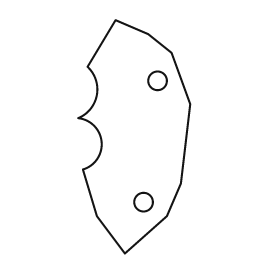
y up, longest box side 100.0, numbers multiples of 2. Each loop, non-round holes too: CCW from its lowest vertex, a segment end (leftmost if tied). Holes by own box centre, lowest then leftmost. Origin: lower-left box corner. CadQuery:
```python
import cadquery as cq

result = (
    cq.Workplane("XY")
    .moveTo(20.0, 0.0)
    .lineTo(38.0, 16.0)
    .lineTo(44.0, 30.0)
    .lineTo(48.0, 64.0)
    .lineTo(40.0, 86.0)
    .lineTo(30.0, 94.0)
    .lineTo(16.0, 100.0)
    .lineTo(4.0, 80.0)
    .threePointArc((8.0, 68.0), (0.0, 58.0))
    .threePointArc((10.0, 48.0), (2.0, 36.0))
    .lineTo(8.0, 16.0)
    .close()
    .moveTo(28.0, 22.0)
    .circle(4.0)
    .moveTo(34.0, 74.0)
    .circle(4.0)
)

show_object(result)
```